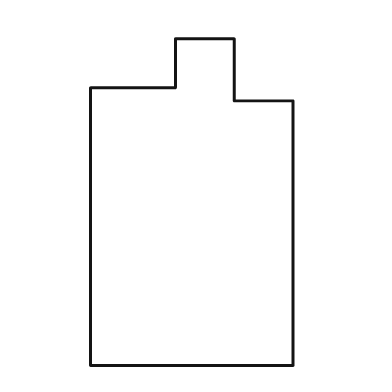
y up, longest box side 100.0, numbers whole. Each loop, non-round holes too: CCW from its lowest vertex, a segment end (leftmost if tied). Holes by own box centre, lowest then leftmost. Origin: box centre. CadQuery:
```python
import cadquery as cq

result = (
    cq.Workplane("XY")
    .moveTo(-31.0, -50.0)
    .lineTo(31.0, -50.0)
    .lineTo(31.0, 31.0)
    .lineTo(13.0, 31.0)
    .lineTo(13.0, 50.0)
    .lineTo(-5.0, 50.0)
    .lineTo(-5.0, 35.0)
    .lineTo(-31.0, 35.0)
    .close()
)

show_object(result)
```